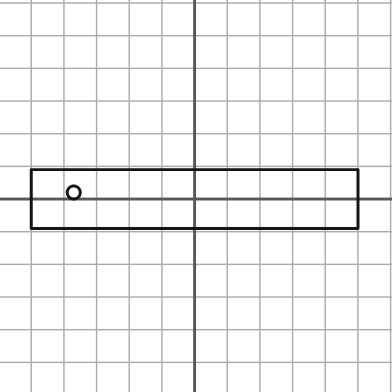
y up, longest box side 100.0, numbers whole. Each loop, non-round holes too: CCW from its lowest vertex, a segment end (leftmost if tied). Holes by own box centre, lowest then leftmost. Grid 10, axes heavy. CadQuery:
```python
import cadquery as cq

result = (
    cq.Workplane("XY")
    .moveTo(-50.0, -9.0)
    .lineTo(50.0, -9.0)
    .lineTo(50.0, 9.0)
    .lineTo(-50.0, 9.0)
    .close()
    .moveTo(-37.0, 2.0)
    .circle(2.0)
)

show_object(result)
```